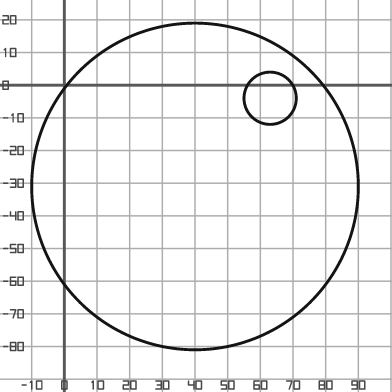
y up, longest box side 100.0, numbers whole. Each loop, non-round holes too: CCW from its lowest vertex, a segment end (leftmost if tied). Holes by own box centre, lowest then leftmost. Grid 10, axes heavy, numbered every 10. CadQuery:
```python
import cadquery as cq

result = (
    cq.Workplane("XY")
    .moveTo(40.0, -31.0)
    .circle(50.0)
    .moveTo(63.0, -4.0)
    .circle(8.0)
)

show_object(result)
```